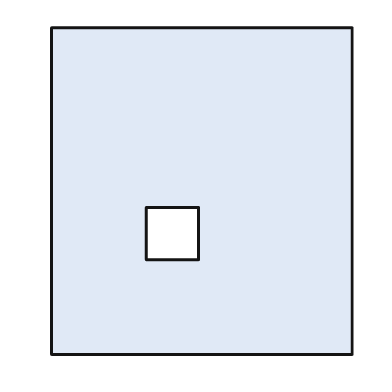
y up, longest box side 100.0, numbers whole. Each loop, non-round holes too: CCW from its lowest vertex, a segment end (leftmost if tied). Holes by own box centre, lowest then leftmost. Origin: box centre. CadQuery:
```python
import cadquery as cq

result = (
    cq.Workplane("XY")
    .moveTo(-46.0, -50.0)
    .lineTo(46.0, -50.0)
    .lineTo(46.0, 50.0)
    .lineTo(-46.0, 50.0)
    .close()
    .moveTo(-17.0, -21.0)
    .lineTo(-1.0, -21.0)
    .lineTo(-1.0, -5.0)
    .lineTo(-17.0, -5.0)
    .close()
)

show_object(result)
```